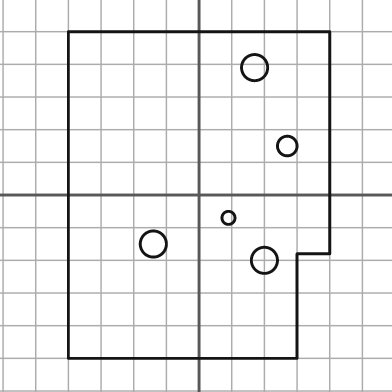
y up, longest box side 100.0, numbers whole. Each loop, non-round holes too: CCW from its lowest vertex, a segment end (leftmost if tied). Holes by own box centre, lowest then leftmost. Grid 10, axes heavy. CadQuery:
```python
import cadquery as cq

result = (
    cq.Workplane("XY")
    .moveTo(-40.0, -50.0)
    .lineTo(30.0, -50.0)
    .lineTo(30.0, -18.0)
    .lineTo(40.0, -18.0)
    .lineTo(40.0, 50.0)
    .lineTo(-40.0, 50.0)
    .close()
    .moveTo(20.0, -20.0)
    .circle(4.0)
    .moveTo(-14.0, -15.0)
    .circle(4.0)
    .moveTo(9.0, -7.0)
    .circle(2.0)
    .moveTo(27.0, 15.0)
    .circle(3.0)
    .moveTo(17.0, 39.0)
    .circle(4.0)
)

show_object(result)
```